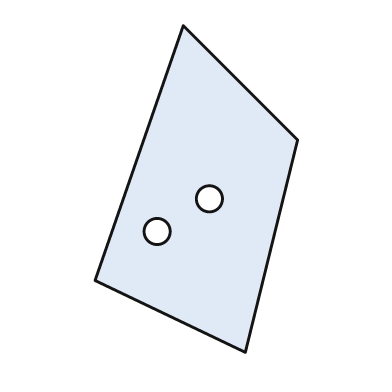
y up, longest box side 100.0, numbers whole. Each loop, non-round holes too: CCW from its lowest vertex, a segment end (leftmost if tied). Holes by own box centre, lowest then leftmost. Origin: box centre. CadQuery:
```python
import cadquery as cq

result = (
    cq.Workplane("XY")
    .moveTo(15.0, -50.0)
    .lineTo(31.0, 15.0)
    .lineTo(-4.0, 50.0)
    .lineTo(-31.0, -28.0)
    .close()
    .moveTo(-12.0, -13.0)
    .circle(4.0)
    .moveTo(4.0, -3.0)
    .circle(4.0)
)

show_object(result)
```